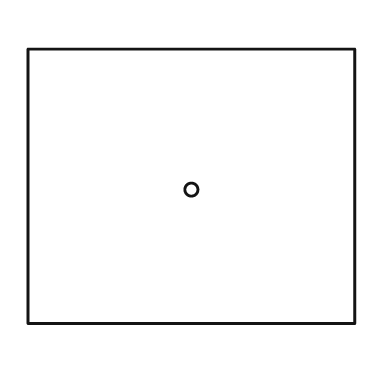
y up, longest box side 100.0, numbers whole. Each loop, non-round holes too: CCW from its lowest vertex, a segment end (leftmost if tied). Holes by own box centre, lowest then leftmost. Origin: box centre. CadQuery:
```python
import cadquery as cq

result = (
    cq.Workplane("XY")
    .moveTo(-50.0, -42.0)
    .lineTo(50.0, -42.0)
    .lineTo(50.0, 42.0)
    .lineTo(-50.0, 42.0)
    .close()
    .moveTo(0.0, -1.0)
    .circle(2.0)
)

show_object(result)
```